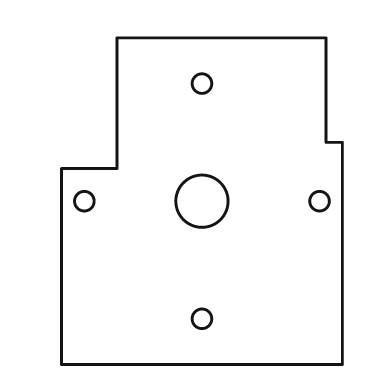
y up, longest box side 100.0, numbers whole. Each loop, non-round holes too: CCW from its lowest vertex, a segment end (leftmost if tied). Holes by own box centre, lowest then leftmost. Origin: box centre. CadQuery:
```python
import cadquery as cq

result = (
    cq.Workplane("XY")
    .moveTo(-43.0, -50.0)
    .lineTo(43.0, -50.0)
    .lineTo(43.0, 18.0)
    .lineTo(38.0, 18.0)
    .lineTo(38.0, 50.0)
    .lineTo(-26.0, 50.0)
    .lineTo(-26.0, 10.0)
    .lineTo(-43.0, 10.0)
    .close()
    .moveTo(0.0, -36.0)
    .circle(3.0)
    .moveTo(-36.0, 0.0)
    .circle(3.0)
    .moveTo(0.0, 0.0)
    .circle(8.0)
    .moveTo(36.0, 0.0)
    .circle(3.0)
    .moveTo(0.0, 36.0)
    .circle(3.0)
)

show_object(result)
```